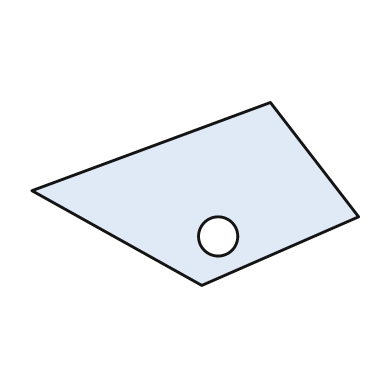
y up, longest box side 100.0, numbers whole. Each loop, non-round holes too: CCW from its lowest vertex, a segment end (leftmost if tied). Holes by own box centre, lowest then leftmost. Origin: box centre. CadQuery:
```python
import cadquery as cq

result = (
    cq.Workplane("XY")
    .moveTo(2.0, -28.0)
    .lineTo(50.0, -7.0)
    .lineTo(23.0, 28.0)
    .lineTo(-50.0, 1.0)
    .close()
    .moveTo(7.0, -13.0)
    .circle(6.0)
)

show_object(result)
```